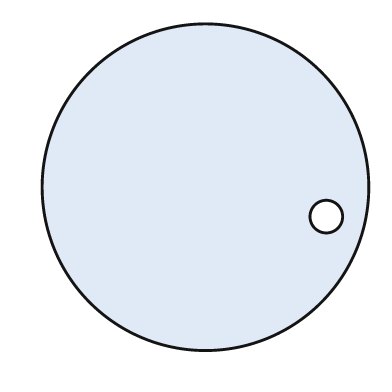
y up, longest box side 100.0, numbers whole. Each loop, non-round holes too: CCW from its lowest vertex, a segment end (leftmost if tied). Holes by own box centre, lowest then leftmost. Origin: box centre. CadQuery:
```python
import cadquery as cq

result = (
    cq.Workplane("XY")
    .moveTo(0.0, 0.0)
    .circle(50.0)
    .moveTo(37.0, -9.0)
    .circle(5.0)
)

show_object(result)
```